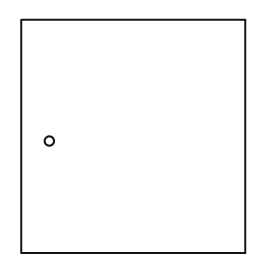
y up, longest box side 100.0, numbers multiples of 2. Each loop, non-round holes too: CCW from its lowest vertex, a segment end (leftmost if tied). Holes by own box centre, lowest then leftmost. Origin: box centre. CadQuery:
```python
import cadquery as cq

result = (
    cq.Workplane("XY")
    .moveTo(-48.0, -50.0)
    .lineTo(48.0, -50.0)
    .lineTo(48.0, 50.0)
    .lineTo(-48.0, 50.0)
    .close()
    .moveTo(-36.0, -2.0)
    .circle(2.0)
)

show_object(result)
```